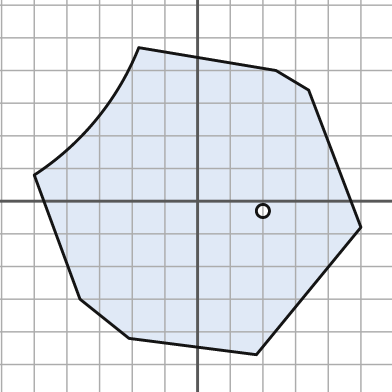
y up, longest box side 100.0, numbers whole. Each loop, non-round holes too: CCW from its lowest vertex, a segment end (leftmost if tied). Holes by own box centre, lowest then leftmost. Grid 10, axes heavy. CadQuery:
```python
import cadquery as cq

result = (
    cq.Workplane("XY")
    .moveTo(18.0, -47.0)
    .lineTo(50.0, -8.0)
    .lineTo(34.0, 34.0)
    .lineTo(24.0, 40.0)
    .lineTo(-18.0, 47.0)
    .threePointArc((-31.0, 25.0), (-50.0, 8.0))
    .lineTo(-36.0, -30.0)
    .lineTo(-21.0, -42.0)
    .close()
    .moveTo(20.0, -3.0)
    .circle(2.0)
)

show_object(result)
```